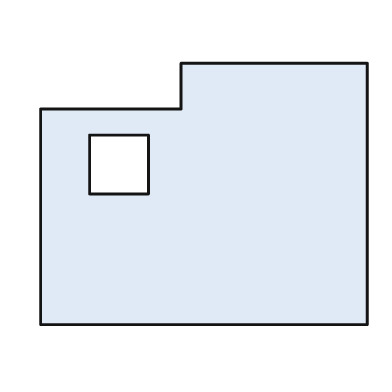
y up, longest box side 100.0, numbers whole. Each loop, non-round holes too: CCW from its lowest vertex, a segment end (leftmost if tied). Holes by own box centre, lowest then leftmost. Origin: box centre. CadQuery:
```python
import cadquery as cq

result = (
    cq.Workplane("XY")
    .moveTo(-50.0, -40.0)
    .lineTo(50.0, -40.0)
    .lineTo(50.0, 40.0)
    .lineTo(-7.0, 40.0)
    .lineTo(-7.0, 26.0)
    .lineTo(-50.0, 26.0)
    .close()
    .moveTo(-35.0, 0.0)
    .lineTo(-17.0, 0.0)
    .lineTo(-17.0, 18.0)
    .lineTo(-35.0, 18.0)
    .close()
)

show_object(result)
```